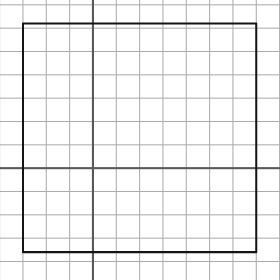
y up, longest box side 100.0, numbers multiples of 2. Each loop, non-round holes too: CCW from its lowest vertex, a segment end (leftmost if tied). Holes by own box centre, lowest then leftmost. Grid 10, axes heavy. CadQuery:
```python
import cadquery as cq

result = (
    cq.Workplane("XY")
    .moveTo(-30.0, -36.0)
    .lineTo(70.0, -36.0)
    .lineTo(70.0, 62.0)
    .lineTo(-30.0, 62.0)
    .close()
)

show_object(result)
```